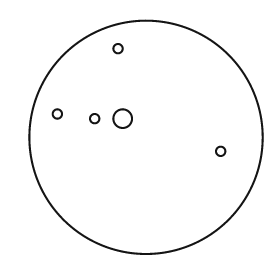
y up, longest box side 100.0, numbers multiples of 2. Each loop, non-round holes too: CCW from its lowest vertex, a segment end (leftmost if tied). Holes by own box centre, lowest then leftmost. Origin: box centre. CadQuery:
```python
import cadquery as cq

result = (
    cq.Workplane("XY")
    .moveTo(0.0, 0.0)
    .circle(50.0)
    .moveTo(32.0, -6.0)
    .circle(2.0)
    .moveTo(-22.0, 8.0)
    .circle(2.0)
    .moveTo(-10.0, 8.0)
    .circle(4.0)
    .moveTo(-38.0, 10.0)
    .circle(2.0)
    .moveTo(-12.0, 38.0)
    .circle(2.0)
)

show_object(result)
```